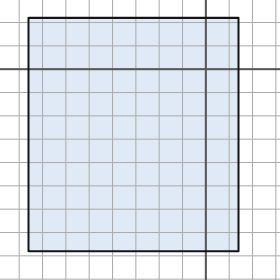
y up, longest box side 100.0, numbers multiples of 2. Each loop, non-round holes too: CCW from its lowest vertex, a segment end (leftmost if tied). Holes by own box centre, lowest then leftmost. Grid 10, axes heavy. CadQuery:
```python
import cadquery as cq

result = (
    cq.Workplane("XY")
    .moveTo(-76.0, -78.0)
    .lineTo(14.0, -78.0)
    .lineTo(14.0, 22.0)
    .lineTo(-76.0, 22.0)
    .close()
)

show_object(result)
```